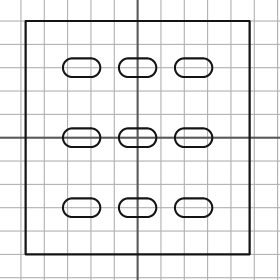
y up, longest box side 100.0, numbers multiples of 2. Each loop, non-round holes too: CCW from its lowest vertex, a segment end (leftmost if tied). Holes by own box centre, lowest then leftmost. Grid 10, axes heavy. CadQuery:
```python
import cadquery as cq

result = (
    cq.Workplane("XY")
    .moveTo(-48.0, -50.0)
    .lineTo(48.0, -50.0)
    .lineTo(48.0, 50.0)
    .lineTo(-48.0, 50.0)
    .close()
    .moveTo(-28.0, -34.0)
    .lineTo(-20.0, -34.0)
    .threePointArc((-16.0, -30.0), (-20.0, -26.0))
    .lineTo(-28.0, -26.0)
    .threePointArc((-32.0, -30.0), (-28.0, -34.0))
    .close()
    .moveTo(-4.0, -34.0)
    .lineTo(4.0, -34.0)
    .threePointArc((8.0, -30.0), (4.0, -26.0))
    .lineTo(-4.0, -26.0)
    .threePointArc((-8.0, -30.0), (-4.0, -34.0))
    .close()
    .moveTo(20.0, -34.0)
    .lineTo(28.0, -34.0)
    .threePointArc((32.0, -30.0), (28.0, -26.0))
    .lineTo(20.0, -26.0)
    .threePointArc((16.0, -30.0), (20.0, -34.0))
    .close()
    .moveTo(-28.0, -4.0)
    .lineTo(-20.0, -4.0)
    .threePointArc((-16.0, 0.0), (-20.0, 4.0))
    .lineTo(-28.0, 4.0)
    .threePointArc((-32.0, 0.0), (-28.0, -4.0))
    .close()
    .moveTo(-4.0, -4.0)
    .lineTo(4.0, -4.0)
    .threePointArc((8.0, 0.0), (4.0, 4.0))
    .lineTo(-4.0, 4.0)
    .threePointArc((-8.0, 0.0), (-4.0, -4.0))
    .close()
    .moveTo(20.0, -4.0)
    .lineTo(28.0, -4.0)
    .threePointArc((32.0, 0.0), (28.0, 4.0))
    .lineTo(20.0, 4.0)
    .threePointArc((16.0, 0.0), (20.0, -4.0))
    .close()
    .moveTo(-28.0, 26.0)
    .lineTo(-20.0, 26.0)
    .threePointArc((-16.0, 30.0), (-20.0, 34.0))
    .lineTo(-28.0, 34.0)
    .threePointArc((-32.0, 30.0), (-28.0, 26.0))
    .close()
    .moveTo(-4.0, 26.0)
    .lineTo(4.0, 26.0)
    .threePointArc((8.0, 30.0), (4.0, 34.0))
    .lineTo(-4.0, 34.0)
    .threePointArc((-8.0, 30.0), (-4.0, 26.0))
    .close()
    .moveTo(20.0, 26.0)
    .lineTo(28.0, 26.0)
    .threePointArc((32.0, 30.0), (28.0, 34.0))
    .lineTo(20.0, 34.0)
    .threePointArc((16.0, 30.0), (20.0, 26.0))
    .close()
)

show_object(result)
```